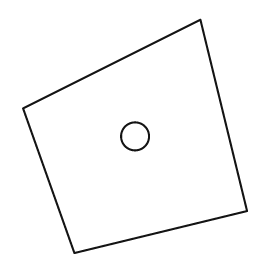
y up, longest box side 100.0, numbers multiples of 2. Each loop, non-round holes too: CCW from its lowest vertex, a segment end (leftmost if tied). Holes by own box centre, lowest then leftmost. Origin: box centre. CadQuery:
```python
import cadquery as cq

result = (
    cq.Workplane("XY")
    .moveTo(-26.0, -50.0)
    .lineTo(48.0, -32.0)
    .lineTo(28.0, 50.0)
    .lineTo(-48.0, 12.0)
    .close()
    .moveTo(0.0, 0.0)
    .circle(6.0)
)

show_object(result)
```